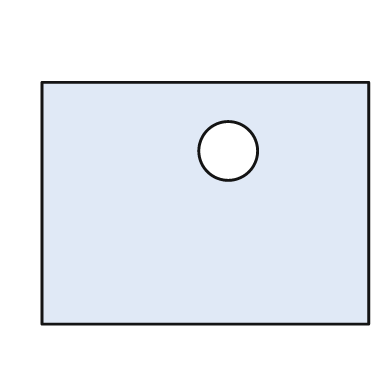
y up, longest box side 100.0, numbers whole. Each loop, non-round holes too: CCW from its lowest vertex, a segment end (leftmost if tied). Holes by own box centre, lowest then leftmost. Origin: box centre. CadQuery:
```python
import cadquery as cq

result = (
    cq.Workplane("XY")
    .moveTo(-50.0, -37.0)
    .lineTo(50.0, -37.0)
    .lineTo(50.0, 37.0)
    .lineTo(-50.0, 37.0)
    .close()
    .moveTo(7.0, 16.0)
    .circle(9.0)
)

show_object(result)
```